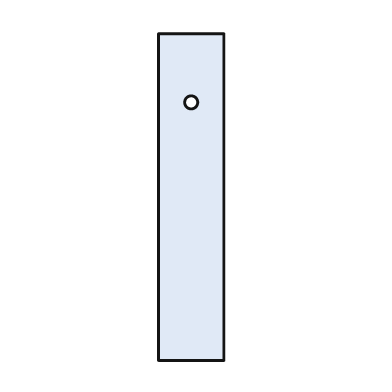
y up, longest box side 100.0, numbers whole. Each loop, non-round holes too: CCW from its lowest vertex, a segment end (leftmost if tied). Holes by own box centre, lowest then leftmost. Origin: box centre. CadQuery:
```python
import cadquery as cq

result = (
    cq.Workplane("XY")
    .moveTo(-10.0, -50.0)
    .lineTo(10.0, -50.0)
    .lineTo(10.0, 50.0)
    .lineTo(-10.0, 50.0)
    .close()
    .moveTo(0.0, 29.0)
    .circle(2.0)
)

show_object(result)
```